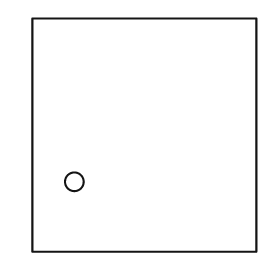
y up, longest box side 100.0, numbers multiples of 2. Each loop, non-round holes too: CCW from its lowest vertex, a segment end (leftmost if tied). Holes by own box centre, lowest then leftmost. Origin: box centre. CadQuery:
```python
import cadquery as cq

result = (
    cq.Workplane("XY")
    .moveTo(-48.0, -50.0)
    .lineTo(48.0, -50.0)
    .lineTo(48.0, 50.0)
    .lineTo(-48.0, 50.0)
    .close()
    .moveTo(-30.0, -20.0)
    .circle(4.0)
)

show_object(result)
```